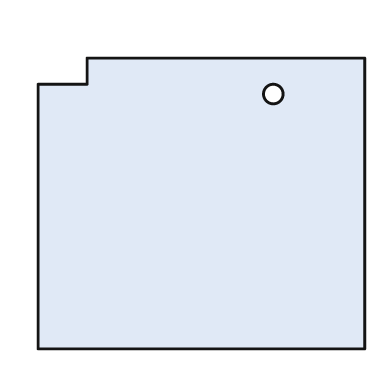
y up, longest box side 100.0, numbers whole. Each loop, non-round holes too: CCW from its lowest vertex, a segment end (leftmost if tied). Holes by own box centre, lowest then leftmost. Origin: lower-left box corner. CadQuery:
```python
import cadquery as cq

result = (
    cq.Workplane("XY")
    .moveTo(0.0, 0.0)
    .lineTo(100.0, 0.0)
    .lineTo(100.0, 89.0)
    .lineTo(15.0, 89.0)
    .lineTo(15.0, 81.0)
    .lineTo(0.0, 81.0)
    .close()
    .moveTo(72.0, 78.0)
    .circle(3.0)
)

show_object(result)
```